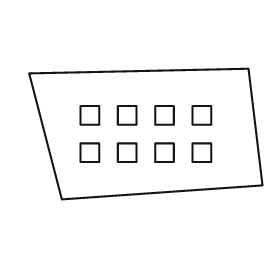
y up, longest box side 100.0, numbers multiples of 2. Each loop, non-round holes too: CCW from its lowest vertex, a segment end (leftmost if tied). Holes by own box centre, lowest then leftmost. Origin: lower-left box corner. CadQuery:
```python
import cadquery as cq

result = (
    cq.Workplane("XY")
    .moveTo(14.0, 0.0)
    .lineTo(100.0, 6.0)
    .lineTo(94.0, 56.0)
    .lineTo(0.0, 54.0)
    .close()
    .moveTo(22.0, 16.0)
    .lineTo(30.0, 16.0)
    .lineTo(30.0, 24.0)
    .lineTo(22.0, 24.0)
    .close()
    .moveTo(38.0, 16.0)
    .lineTo(46.0, 16.0)
    .lineTo(46.0, 24.0)
    .lineTo(38.0, 24.0)
    .close()
    .moveTo(54.0, 16.0)
    .lineTo(62.0, 16.0)
    .lineTo(62.0, 24.0)
    .lineTo(54.0, 24.0)
    .close()
    .moveTo(70.0, 16.0)
    .lineTo(78.0, 16.0)
    .lineTo(78.0, 24.0)
    .lineTo(70.0, 24.0)
    .close()
    .moveTo(22.0, 32.0)
    .lineTo(30.0, 32.0)
    .lineTo(30.0, 40.0)
    .lineTo(22.0, 40.0)
    .close()
    .moveTo(38.0, 32.0)
    .lineTo(46.0, 32.0)
    .lineTo(46.0, 40.0)
    .lineTo(38.0, 40.0)
    .close()
    .moveTo(54.0, 32.0)
    .lineTo(62.0, 32.0)
    .lineTo(62.0, 40.0)
    .lineTo(54.0, 40.0)
    .close()
    .moveTo(70.0, 32.0)
    .lineTo(78.0, 32.0)
    .lineTo(78.0, 40.0)
    .lineTo(70.0, 40.0)
    .close()
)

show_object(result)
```